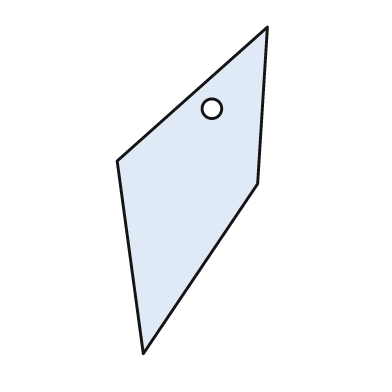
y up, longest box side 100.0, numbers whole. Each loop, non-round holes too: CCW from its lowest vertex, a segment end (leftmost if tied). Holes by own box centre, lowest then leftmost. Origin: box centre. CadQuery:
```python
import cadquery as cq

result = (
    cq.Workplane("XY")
    .moveTo(-15.0, -50.0)
    .lineTo(20.0, 2.0)
    .lineTo(23.0, 50.0)
    .lineTo(-23.0, 9.0)
    .close()
    .moveTo(6.0, 25.0)
    .circle(3.0)
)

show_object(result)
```